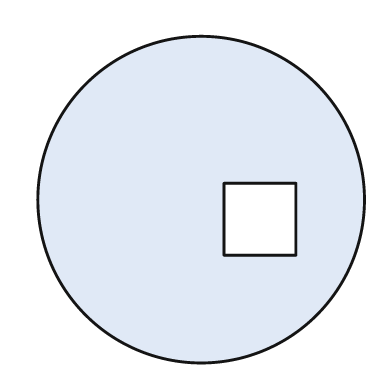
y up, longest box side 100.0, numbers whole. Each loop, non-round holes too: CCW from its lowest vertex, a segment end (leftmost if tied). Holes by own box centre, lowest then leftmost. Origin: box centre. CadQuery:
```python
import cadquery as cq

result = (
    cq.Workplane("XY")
    .moveTo(0.0, 0.0)
    .circle(50.0)
    .moveTo(7.0, -17.0)
    .lineTo(29.0, -17.0)
    .lineTo(29.0, 5.0)
    .lineTo(7.0, 5.0)
    .close()
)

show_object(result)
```